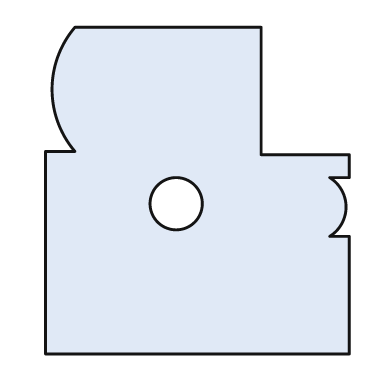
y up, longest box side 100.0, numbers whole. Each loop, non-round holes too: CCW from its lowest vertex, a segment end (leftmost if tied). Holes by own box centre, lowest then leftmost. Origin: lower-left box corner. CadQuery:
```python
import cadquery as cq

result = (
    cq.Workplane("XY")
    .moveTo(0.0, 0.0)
    .lineTo(93.0, 0.0)
    .lineTo(93.0, 36.0)
    .lineTo(87.0, 36.0)
    .threePointArc((92.0, 45.0), (87.0, 54.0))
    .lineTo(93.0, 54.0)
    .lineTo(93.0, 61.0)
    .lineTo(66.0, 61.0)
    .lineTo(66.0, 100.0)
    .lineTo(9.0, 100.0)
    .threePointArc((2.0, 81.0), (9.0, 62.0))
    .lineTo(0.0, 62.0)
    .close()
    .moveTo(40.0, 46.0)
    .circle(8.0)
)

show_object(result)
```